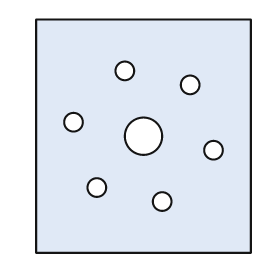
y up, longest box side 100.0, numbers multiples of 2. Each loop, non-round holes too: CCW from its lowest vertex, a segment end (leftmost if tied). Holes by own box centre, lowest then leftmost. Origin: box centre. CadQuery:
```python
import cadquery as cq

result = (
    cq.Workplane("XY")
    .moveTo(-46.0, -50.0)
    .lineTo(46.0, -50.0)
    .lineTo(46.0, 50.0)
    .lineTo(-46.0, 50.0)
    .close()
    .moveTo(8.0, -28.0)
    .circle(4.0)
    .moveTo(-20.0, -22.0)
    .circle(4.0)
    .moveTo(30.0, -6.0)
    .circle(4.0)
    .moveTo(0.0, 0.0)
    .circle(8.0)
    .moveTo(-30.0, 6.0)
    .circle(4.0)
    .moveTo(20.0, 22.0)
    .circle(4.0)
    .moveTo(-8.0, 28.0)
    .circle(4.0)
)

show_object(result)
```